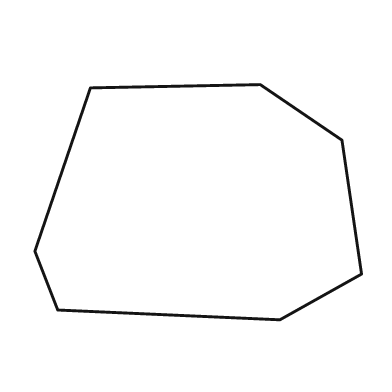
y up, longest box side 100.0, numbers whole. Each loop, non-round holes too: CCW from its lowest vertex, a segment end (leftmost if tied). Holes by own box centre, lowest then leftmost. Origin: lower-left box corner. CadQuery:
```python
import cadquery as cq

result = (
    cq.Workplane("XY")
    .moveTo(75.0, 0.0)
    .lineTo(100.0, 14.0)
    .lineTo(94.0, 55.0)
    .lineTo(69.0, 72.0)
    .lineTo(17.0, 71.0)
    .lineTo(0.0, 21.0)
    .lineTo(7.0, 3.0)
    .close()
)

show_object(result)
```